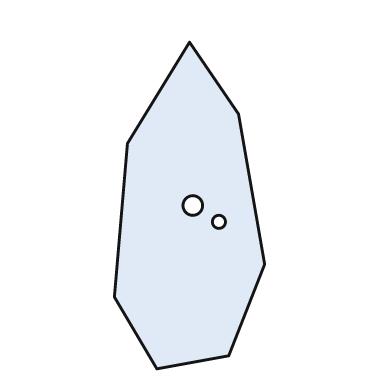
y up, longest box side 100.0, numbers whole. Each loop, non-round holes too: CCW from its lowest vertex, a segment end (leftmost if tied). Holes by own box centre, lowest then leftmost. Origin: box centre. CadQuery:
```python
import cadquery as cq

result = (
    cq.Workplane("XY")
    .moveTo(-10.0, -50.0)
    .lineTo(12.0, -46.0)
    .lineTo(23.0, -18.0)
    .lineTo(15.0, 28.0)
    .lineTo(0.0, 50.0)
    .lineTo(-19.0, 19.0)
    .lineTo(-23.0, -28.0)
    .close()
    .moveTo(9.0, -5.0)
    .circle(2.0)
    .moveTo(1.0, 0.0)
    .circle(3.0)
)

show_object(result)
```